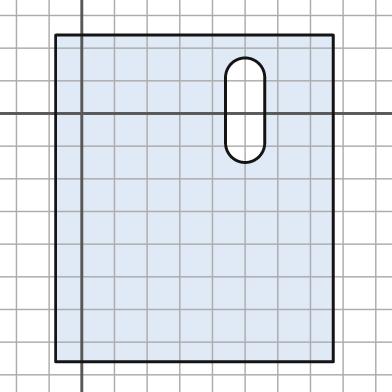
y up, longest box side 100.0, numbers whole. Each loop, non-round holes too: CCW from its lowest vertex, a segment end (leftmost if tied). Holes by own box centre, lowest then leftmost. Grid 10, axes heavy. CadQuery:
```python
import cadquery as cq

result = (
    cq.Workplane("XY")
    .moveTo(-8.0, -76.0)
    .lineTo(77.0, -76.0)
    .lineTo(77.0, 24.0)
    .lineTo(-8.0, 24.0)
    .close()
    .moveTo(44.0, -9.0)
    .threePointArc((50.0, -15.0), (56.0, -9.0))
    .lineTo(56.0, 11.0)
    .threePointArc((50.0, 17.0), (44.0, 11.0))
    .close()
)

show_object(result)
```